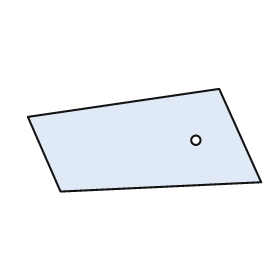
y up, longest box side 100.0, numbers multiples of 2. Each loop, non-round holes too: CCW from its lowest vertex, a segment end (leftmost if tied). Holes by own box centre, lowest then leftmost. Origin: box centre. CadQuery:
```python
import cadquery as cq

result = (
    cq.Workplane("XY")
    .moveTo(-36.0, -22.0)
    .lineTo(50.0, -18.0)
    .lineTo(32.0, 22.0)
    .lineTo(-50.0, 10.0)
    .close()
    .moveTo(22.0, 0.0)
    .circle(2.0)
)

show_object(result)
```